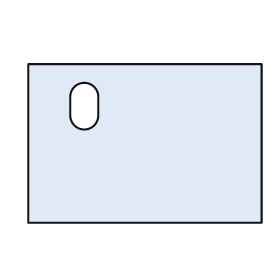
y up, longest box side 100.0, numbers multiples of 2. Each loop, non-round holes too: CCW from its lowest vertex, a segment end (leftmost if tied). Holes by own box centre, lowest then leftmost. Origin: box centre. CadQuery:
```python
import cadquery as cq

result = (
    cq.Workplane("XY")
    .moveTo(-50.0, -34.0)
    .lineTo(50.0, -34.0)
    .lineTo(50.0, 34.0)
    .lineTo(-50.0, 34.0)
    .close()
    .moveTo(-32.0, 12.0)
    .threePointArc((-26.0, 6.0), (-20.0, 12.0))
    .lineTo(-20.0, 20.0)
    .threePointArc((-26.0, 26.0), (-32.0, 20.0))
    .close()
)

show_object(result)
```